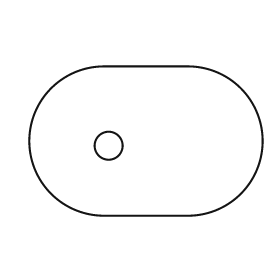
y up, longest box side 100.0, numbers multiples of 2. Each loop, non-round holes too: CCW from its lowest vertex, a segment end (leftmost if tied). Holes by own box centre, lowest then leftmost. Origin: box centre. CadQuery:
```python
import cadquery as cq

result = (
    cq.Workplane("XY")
    .moveTo(-18.0, -32.0)
    .lineTo(18.0, -32.0)
    .threePointArc((50.0, 0.0), (18.0, 32.0))
    .lineTo(-18.0, 32.0)
    .threePointArc((-50.0, 0.0), (-18.0, -32.0))
    .close()
    .moveTo(-16.0, -2.0)
    .circle(6.0)
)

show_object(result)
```